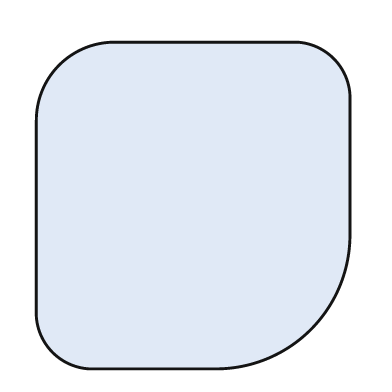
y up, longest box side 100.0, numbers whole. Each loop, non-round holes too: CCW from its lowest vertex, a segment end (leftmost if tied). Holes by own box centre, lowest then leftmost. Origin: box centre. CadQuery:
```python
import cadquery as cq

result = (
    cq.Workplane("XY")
    .moveTo(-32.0, -50.0)
    .lineTo(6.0, -50.0)
    .threePointArc((36.0, -38.0), (48.0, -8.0))
    .lineTo(48.0, 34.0)
    .threePointArc((43.0, 45.0), (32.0, 50.0))
    .lineTo(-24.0, 50.0)
    .threePointArc((-41.0, 43.0), (-48.0, 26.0))
    .lineTo(-48.0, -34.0)
    .threePointArc((-43.0, -45.0), (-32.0, -50.0))
    .close()
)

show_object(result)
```